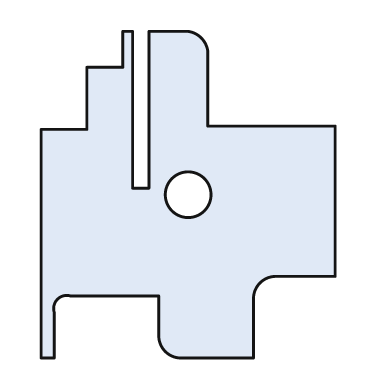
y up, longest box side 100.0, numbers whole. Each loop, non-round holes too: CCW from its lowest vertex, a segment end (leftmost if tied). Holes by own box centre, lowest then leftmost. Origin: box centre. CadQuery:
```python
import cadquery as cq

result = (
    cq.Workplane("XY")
    .moveTo(-45.0, -50.0)
    .lineTo(-41.0, -50.0)
    .lineTo(-41.0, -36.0)
    .threePointArc((-40.0, -32.0), (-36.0, -31.0))
    .lineTo(-9.0, -31.0)
    .lineTo(-9.0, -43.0)
    .threePointArc((-7.0, -48.0), (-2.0, -50.0))
    .lineTo(20.0, -50.0)
    .lineTo(20.0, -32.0)
    .threePointArc((22.0, -27.0), (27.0, -25.0))
    .lineTo(45.0, -25.0)
    .lineTo(45.0, 21.0)
    .lineTo(6.0, 21.0)
    .lineTo(6.0, 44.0)
    .threePointArc((4.0, 48.0), (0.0, 50.0))
    .lineTo(-12.0, 50.0)
    .lineTo(-12.0, 2.0)
    .lineTo(-17.0, 2.0)
    .lineTo(-17.0, 50.0)
    .lineTo(-20.0, 50.0)
    .lineTo(-20.0, 39.0)
    .lineTo(-31.0, 39.0)
    .lineTo(-31.0, 20.0)
    .lineTo(-45.0, 20.0)
    .close()
    .moveTo(0.0, 0.0)
    .circle(7.0)
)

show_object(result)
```